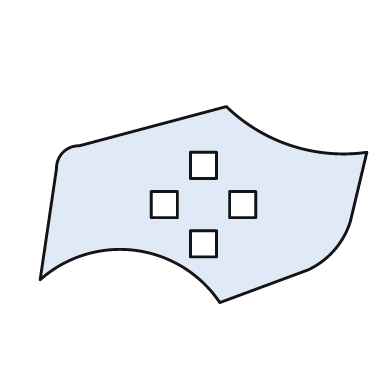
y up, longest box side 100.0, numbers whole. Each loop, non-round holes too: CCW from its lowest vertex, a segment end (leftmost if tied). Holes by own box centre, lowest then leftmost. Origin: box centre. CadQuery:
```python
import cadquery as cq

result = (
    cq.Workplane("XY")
    .moveTo(5.0, -30.0)
    .lineTo(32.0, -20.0)
    .threePointArc((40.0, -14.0), (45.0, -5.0))
    .lineTo(50.0, 16.0)
    .threePointArc((27.0, 18.0), (7.0, 30.0))
    .lineTo(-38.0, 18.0)
    .threePointArc((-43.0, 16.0), (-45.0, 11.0))
    .lineTo(-50.0, -23.0)
    .threePointArc((-21.0, -14.0), (5.0, -30.0))
    .close()
    .moveTo(-4.0, -16.0)
    .lineTo(4.0, -16.0)
    .lineTo(4.0, -8.0)
    .lineTo(-4.0, -8.0)
    .close()
    .moveTo(-16.0, -4.0)
    .lineTo(-8.0, -4.0)
    .lineTo(-8.0, 4.0)
    .lineTo(-16.0, 4.0)
    .close()
    .moveTo(8.0, -4.0)
    .lineTo(16.0, -4.0)
    .lineTo(16.0, 4.0)
    .lineTo(8.0, 4.0)
    .close()
    .moveTo(-4.0, 8.0)
    .lineTo(4.0, 8.0)
    .lineTo(4.0, 16.0)
    .lineTo(-4.0, 16.0)
    .close()
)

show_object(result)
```